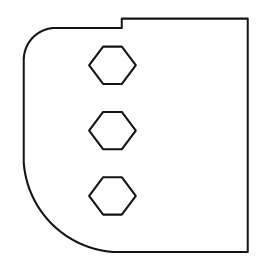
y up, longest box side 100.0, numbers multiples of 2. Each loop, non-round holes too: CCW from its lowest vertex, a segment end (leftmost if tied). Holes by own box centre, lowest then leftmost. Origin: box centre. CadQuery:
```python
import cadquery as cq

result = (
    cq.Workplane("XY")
    .moveTo(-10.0, -50.0)
    .lineTo(48.0, -50.0)
    .lineTo(48.0, 50.0)
    .lineTo(-6.0, 50.0)
    .lineTo(-6.0, 46.0)
    .lineTo(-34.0, 46.0)
    .threePointArc((-44.0, 42.0), (-48.0, 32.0))
    .lineTo(-48.0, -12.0)
    .threePointArc((-36.0, -38.0), (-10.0, -50.0))
    .close()
    .moveTo(-14.0, -34.0)
    .lineTo(-6.0, -34.0)
    .lineTo(0.0, -26.0)
    .lineTo(-6.0, -18.0)
    .lineTo(-14.0, -18.0)
    .lineTo(-20.0, -26.0)
    .close()
    .moveTo(-14.0, -6.0)
    .lineTo(-6.0, -6.0)
    .lineTo(0.0, 2.0)
    .lineTo(-6.0, 10.0)
    .lineTo(-14.0, 10.0)
    .lineTo(-20.0, 2.0)
    .close()
    .moveTo(-14.0, 22.0)
    .lineTo(-6.0, 22.0)
    .lineTo(0.0, 30.0)
    .lineTo(-6.0, 38.0)
    .lineTo(-14.0, 38.0)
    .lineTo(-20.0, 30.0)
    .close()
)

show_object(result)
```